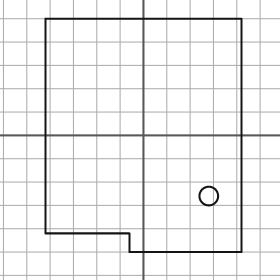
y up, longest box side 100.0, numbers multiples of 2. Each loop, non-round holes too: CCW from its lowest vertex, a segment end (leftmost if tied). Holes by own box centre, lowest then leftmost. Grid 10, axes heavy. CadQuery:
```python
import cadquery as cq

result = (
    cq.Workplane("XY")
    .moveTo(-6.0, -50.0)
    .lineTo(42.0, -50.0)
    .lineTo(42.0, 50.0)
    .lineTo(-42.0, 50.0)
    .lineTo(-42.0, -42.0)
    .lineTo(-6.0, -42.0)
    .close()
    .moveTo(28.0, -26.0)
    .circle(4.0)
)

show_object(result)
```